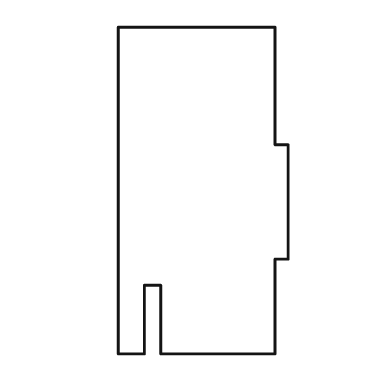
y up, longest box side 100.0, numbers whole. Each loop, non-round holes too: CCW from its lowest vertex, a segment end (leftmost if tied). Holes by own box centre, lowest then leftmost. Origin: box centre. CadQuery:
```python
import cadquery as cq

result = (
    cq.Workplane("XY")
    .moveTo(-26.0, -50.0)
    .lineTo(-18.0, -50.0)
    .lineTo(-18.0, -29.0)
    .lineTo(-13.0, -29.0)
    .lineTo(-13.0, -50.0)
    .lineTo(22.0, -50.0)
    .lineTo(22.0, -21.0)
    .lineTo(26.0, -21.0)
    .lineTo(26.0, 14.0)
    .lineTo(22.0, 14.0)
    .lineTo(22.0, 50.0)
    .lineTo(-26.0, 50.0)
    .close()
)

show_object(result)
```